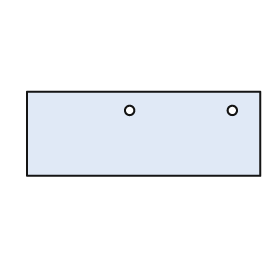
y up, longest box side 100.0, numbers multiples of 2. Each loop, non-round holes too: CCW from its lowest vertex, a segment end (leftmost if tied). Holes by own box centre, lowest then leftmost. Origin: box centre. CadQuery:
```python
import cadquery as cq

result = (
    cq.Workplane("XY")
    .moveTo(-50.0, -18.0)
    .lineTo(50.0, -18.0)
    .lineTo(50.0, 18.0)
    .lineTo(-50.0, 18.0)
    .close()
    .moveTo(-6.0, 10.0)
    .circle(2.0)
    .moveTo(38.0, 10.0)
    .circle(2.0)
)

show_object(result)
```